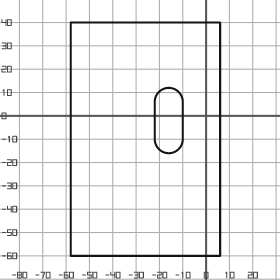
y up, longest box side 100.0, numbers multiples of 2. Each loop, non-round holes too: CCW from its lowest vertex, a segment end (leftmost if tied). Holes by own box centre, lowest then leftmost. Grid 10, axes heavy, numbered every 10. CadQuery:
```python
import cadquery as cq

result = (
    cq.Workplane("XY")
    .moveTo(-58.0, -60.0)
    .lineTo(6.0, -60.0)
    .lineTo(6.0, 40.0)
    .lineTo(-58.0, 40.0)
    .close()
    .moveTo(-22.0, -10.0)
    .threePointArc((-16.0, -16.0), (-10.0, -10.0))
    .lineTo(-10.0, 6.0)
    .threePointArc((-16.0, 12.0), (-22.0, 6.0))
    .close()
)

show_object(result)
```